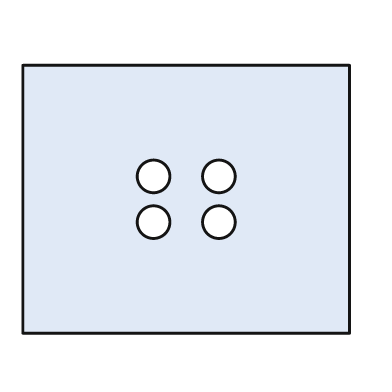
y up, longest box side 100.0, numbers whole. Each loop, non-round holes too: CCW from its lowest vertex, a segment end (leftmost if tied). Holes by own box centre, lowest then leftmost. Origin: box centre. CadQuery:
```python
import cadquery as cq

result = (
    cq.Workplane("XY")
    .moveTo(-50.0, -41.0)
    .lineTo(50.0, -41.0)
    .lineTo(50.0, 41.0)
    .lineTo(-50.0, 41.0)
    .close()
    .moveTo(-10.0, -7.0)
    .circle(5.0)
    .moveTo(10.0, -7.0)
    .circle(5.0)
    .moveTo(-10.0, 7.0)
    .circle(5.0)
    .moveTo(10.0, 7.0)
    .circle(5.0)
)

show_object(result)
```